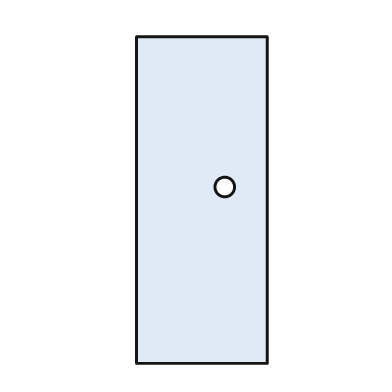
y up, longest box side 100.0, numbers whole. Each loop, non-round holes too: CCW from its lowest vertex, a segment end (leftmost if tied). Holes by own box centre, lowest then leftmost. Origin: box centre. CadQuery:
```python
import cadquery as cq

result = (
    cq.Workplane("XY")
    .moveTo(-20.0, -50.0)
    .lineTo(20.0, -50.0)
    .lineTo(20.0, 50.0)
    .lineTo(-20.0, 50.0)
    .close()
    .moveTo(7.0, 4.0)
    .circle(3.0)
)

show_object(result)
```